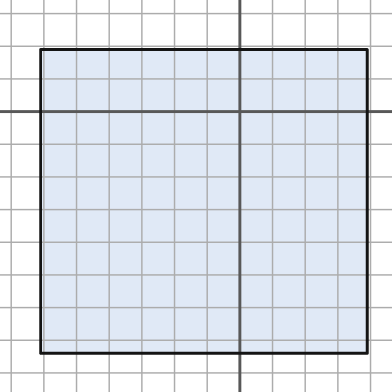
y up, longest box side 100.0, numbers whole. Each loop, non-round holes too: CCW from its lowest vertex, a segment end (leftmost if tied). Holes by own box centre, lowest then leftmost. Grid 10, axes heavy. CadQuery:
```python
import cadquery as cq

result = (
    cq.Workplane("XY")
    .moveTo(-61.0, -74.0)
    .lineTo(39.0, -74.0)
    .lineTo(39.0, 19.0)
    .lineTo(-61.0, 19.0)
    .close()
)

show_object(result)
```